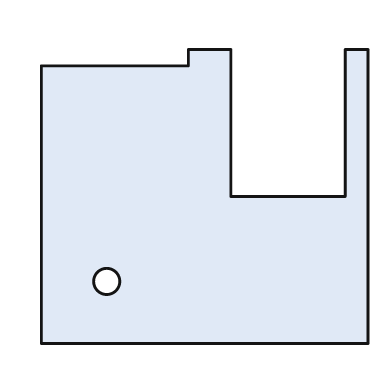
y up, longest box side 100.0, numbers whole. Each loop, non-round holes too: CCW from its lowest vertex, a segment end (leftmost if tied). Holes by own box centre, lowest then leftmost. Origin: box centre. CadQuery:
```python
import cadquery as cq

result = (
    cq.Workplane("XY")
    .moveTo(-50.0, -45.0)
    .lineTo(50.0, -45.0)
    .lineTo(50.0, 45.0)
    .lineTo(43.0, 45.0)
    .lineTo(43.0, 0.0)
    .lineTo(8.0, 0.0)
    .lineTo(8.0, 45.0)
    .lineTo(-5.0, 45.0)
    .lineTo(-5.0, 40.0)
    .lineTo(-50.0, 40.0)
    .close()
    .moveTo(-30.0, -26.0)
    .circle(4.0)
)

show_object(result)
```